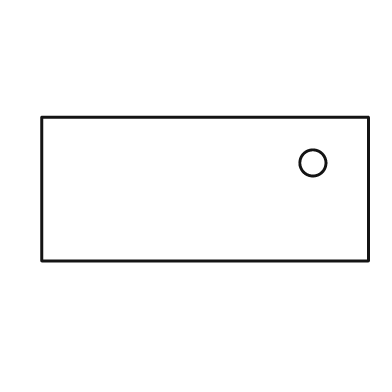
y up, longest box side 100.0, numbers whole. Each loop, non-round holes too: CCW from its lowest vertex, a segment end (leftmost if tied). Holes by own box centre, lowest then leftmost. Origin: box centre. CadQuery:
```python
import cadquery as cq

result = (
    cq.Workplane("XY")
    .moveTo(-50.0, -22.0)
    .lineTo(50.0, -22.0)
    .lineTo(50.0, 22.0)
    .lineTo(-50.0, 22.0)
    .close()
    .moveTo(33.0, 8.0)
    .circle(4.0)
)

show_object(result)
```